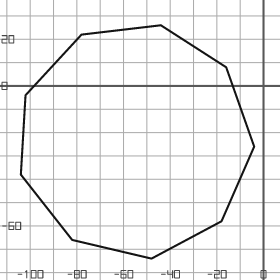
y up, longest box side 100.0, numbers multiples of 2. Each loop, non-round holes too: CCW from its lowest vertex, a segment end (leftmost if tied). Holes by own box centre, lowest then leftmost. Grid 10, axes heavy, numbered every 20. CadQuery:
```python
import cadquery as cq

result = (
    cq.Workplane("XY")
    .moveTo(-48.0, -74.0)
    .lineTo(-18.0, -58.0)
    .lineTo(-4.0, -26.0)
    .lineTo(-16.0, 8.0)
    .lineTo(-44.0, 26.0)
    .lineTo(-78.0, 22.0)
    .lineTo(-102.0, -4.0)
    .lineTo(-104.0, -38.0)
    .lineTo(-82.0, -66.0)
    .close()
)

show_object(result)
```